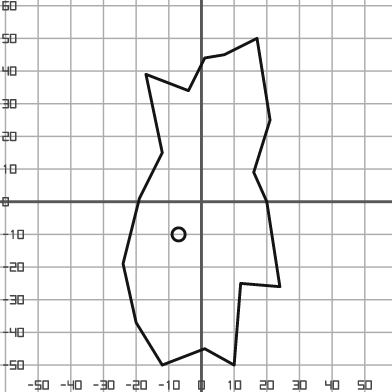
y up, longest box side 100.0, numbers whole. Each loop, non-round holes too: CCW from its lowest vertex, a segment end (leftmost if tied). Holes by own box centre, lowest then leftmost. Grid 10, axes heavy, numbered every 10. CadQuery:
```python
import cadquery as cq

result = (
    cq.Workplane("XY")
    .moveTo(-12.0, -50.0)
    .lineTo(1.0, -45.0)
    .lineTo(10.0, -50.0)
    .lineTo(12.0, -25.0)
    .lineTo(24.0, -26.0)
    .lineTo(20.0, 0.0)
    .lineTo(16.0, 9.0)
    .lineTo(21.0, 25.0)
    .lineTo(17.0, 50.0)
    .lineTo(7.0, 45.0)
    .lineTo(1.0, 44.0)
    .lineTo(-4.0, 34.0)
    .lineTo(-17.0, 39.0)
    .lineTo(-12.0, 15.0)
    .lineTo(-19.0, 1.0)
    .lineTo(-24.0, -19.0)
    .lineTo(-20.0, -37.0)
    .close()
    .moveTo(-7.0, -10.0)
    .circle(2.0)
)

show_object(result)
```